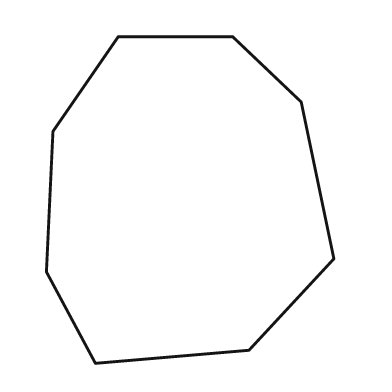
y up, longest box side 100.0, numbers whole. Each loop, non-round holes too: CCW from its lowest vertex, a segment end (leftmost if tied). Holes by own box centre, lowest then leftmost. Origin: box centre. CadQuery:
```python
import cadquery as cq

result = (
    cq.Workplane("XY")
    .moveTo(-29.0, -50.0)
    .lineTo(18.0, -46.0)
    .lineTo(44.0, -18.0)
    .lineTo(34.0, 30.0)
    .lineTo(13.0, 50.0)
    .lineTo(-22.0, 50.0)
    .lineTo(-42.0, 21.0)
    .lineTo(-44.0, -22.0)
    .close()
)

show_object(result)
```